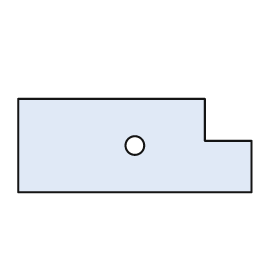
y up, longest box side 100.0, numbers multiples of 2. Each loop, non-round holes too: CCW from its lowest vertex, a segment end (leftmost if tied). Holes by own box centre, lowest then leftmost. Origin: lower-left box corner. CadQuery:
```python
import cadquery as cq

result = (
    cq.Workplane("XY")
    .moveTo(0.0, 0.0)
    .lineTo(100.0, 0.0)
    .lineTo(100.0, 22.0)
    .lineTo(80.0, 22.0)
    .lineTo(80.0, 40.0)
    .lineTo(0.0, 40.0)
    .close()
    .moveTo(50.0, 20.0)
    .circle(4.0)
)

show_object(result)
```